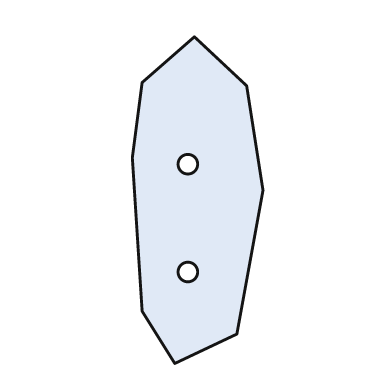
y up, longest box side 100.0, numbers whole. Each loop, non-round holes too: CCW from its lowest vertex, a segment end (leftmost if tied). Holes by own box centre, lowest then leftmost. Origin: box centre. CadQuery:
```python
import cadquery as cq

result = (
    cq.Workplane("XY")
    .moveTo(-7.0, -50.0)
    .lineTo(12.0, -41.0)
    .lineTo(20.0, 3.0)
    .lineTo(15.0, 35.0)
    .lineTo(-1.0, 50.0)
    .lineTo(-17.0, 36.0)
    .lineTo(-20.0, 13.0)
    .lineTo(-17.0, -34.0)
    .close()
    .moveTo(-3.0, -22.0)
    .circle(3.0)
    .moveTo(-3.0, 11.0)
    .circle(3.0)
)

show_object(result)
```